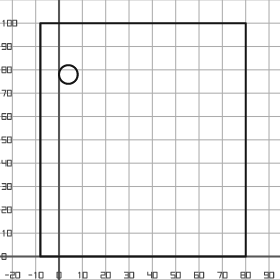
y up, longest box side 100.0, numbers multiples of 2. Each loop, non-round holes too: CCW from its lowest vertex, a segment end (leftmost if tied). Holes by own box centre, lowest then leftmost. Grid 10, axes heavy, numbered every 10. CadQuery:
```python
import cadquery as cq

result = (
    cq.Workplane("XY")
    .moveTo(-8.0, 0.0)
    .lineTo(80.0, 0.0)
    .lineTo(80.0, 100.0)
    .lineTo(-8.0, 100.0)
    .close()
    .moveTo(4.0, 78.0)
    .circle(4.0)
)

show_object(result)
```